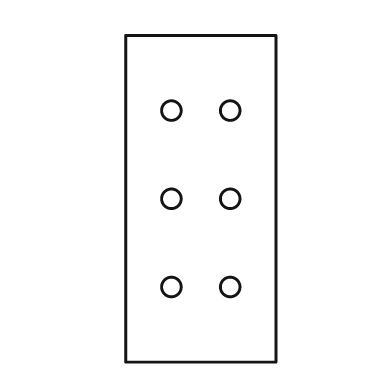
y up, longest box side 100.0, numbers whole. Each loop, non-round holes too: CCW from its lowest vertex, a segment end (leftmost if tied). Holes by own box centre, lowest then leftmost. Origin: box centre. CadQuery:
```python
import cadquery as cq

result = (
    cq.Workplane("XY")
    .moveTo(-23.0, -50.0)
    .lineTo(23.0, -50.0)
    .lineTo(23.0, 50.0)
    .lineTo(-23.0, 50.0)
    .close()
    .moveTo(-9.0, -27.0)
    .circle(3.0)
    .moveTo(9.0, -27.0)
    .circle(3.0)
    .moveTo(-9.0, 0.0)
    .circle(3.0)
    .moveTo(9.0, 0.0)
    .circle(3.0)
    .moveTo(-9.0, 27.0)
    .circle(3.0)
    .moveTo(9.0, 27.0)
    .circle(3.0)
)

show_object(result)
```